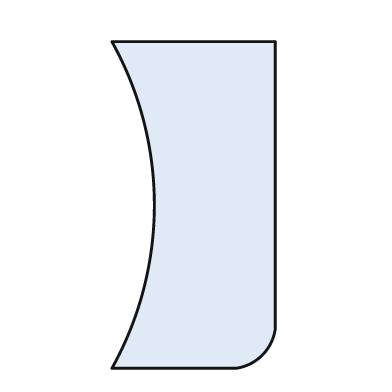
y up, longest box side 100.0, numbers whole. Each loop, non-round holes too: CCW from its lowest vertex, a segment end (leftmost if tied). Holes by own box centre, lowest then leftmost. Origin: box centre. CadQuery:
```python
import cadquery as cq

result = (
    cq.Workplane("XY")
    .moveTo(-25.0, -50.0)
    .lineTo(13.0, -50.0)
    .threePointArc((21.0, -46.0), (25.0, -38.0))
    .lineTo(25.0, 50.0)
    .lineTo(-25.0, 50.0)
    .threePointArc((-12.0, 0.0), (-25.0, -50.0))
    .close()
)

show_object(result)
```